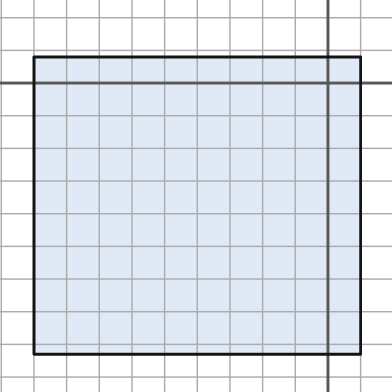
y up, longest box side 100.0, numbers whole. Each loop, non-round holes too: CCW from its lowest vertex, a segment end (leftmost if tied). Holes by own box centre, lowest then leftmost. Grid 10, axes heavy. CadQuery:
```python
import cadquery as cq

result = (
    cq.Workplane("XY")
    .moveTo(-90.0, -83.0)
    .lineTo(10.0, -83.0)
    .lineTo(10.0, 8.0)
    .lineTo(-90.0, 8.0)
    .close()
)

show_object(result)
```